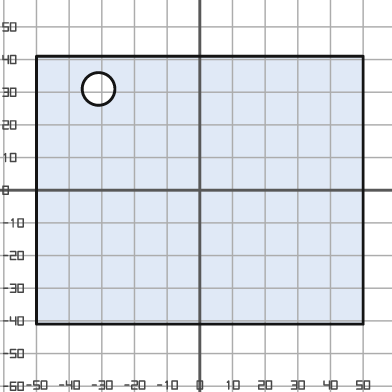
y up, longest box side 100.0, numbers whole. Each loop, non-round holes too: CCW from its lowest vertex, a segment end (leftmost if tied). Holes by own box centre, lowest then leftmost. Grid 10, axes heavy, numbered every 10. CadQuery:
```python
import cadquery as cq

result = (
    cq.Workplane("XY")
    .moveTo(-50.0, -41.0)
    .lineTo(50.0, -41.0)
    .lineTo(50.0, 41.0)
    .lineTo(-50.0, 41.0)
    .close()
    .moveTo(-31.0, 31.0)
    .circle(5.0)
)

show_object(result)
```